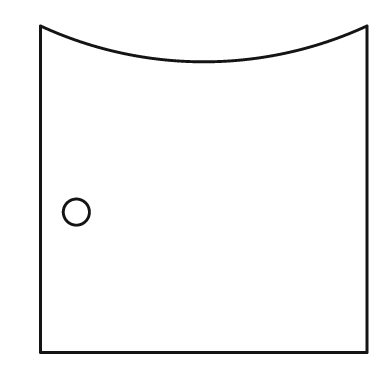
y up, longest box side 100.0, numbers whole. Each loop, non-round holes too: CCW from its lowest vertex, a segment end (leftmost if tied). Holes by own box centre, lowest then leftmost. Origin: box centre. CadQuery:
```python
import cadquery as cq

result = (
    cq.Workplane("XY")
    .moveTo(-50.0, -50.0)
    .lineTo(50.0, -50.0)
    .lineTo(50.0, 50.0)
    .threePointArc((0.0, 39.0), (-50.0, 50.0))
    .close()
    .moveTo(-39.0, -7.0)
    .circle(4.0)
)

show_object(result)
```